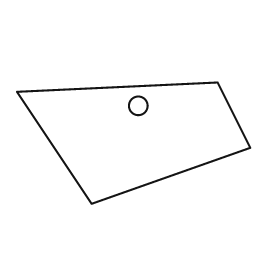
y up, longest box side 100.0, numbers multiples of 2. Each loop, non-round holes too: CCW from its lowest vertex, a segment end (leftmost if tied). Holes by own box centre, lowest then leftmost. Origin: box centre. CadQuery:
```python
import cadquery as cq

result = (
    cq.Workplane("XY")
    .moveTo(-18.0, -26.0)
    .lineTo(50.0, -2.0)
    .lineTo(36.0, 26.0)
    .lineTo(-50.0, 22.0)
    .close()
    .moveTo(2.0, 16.0)
    .circle(4.0)
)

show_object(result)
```